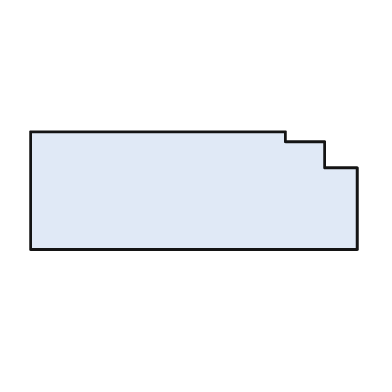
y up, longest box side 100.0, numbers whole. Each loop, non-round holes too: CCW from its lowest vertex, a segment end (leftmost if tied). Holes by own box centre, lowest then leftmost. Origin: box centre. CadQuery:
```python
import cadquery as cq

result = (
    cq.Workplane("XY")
    .moveTo(-50.0, -18.0)
    .lineTo(50.0, -18.0)
    .lineTo(50.0, 7.0)
    .lineTo(40.0, 7.0)
    .lineTo(40.0, 15.0)
    .lineTo(28.0, 15.0)
    .lineTo(28.0, 18.0)
    .lineTo(-50.0, 18.0)
    .close()
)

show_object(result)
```